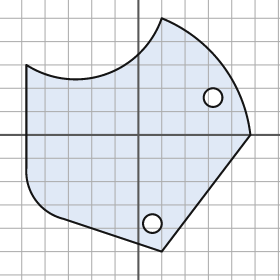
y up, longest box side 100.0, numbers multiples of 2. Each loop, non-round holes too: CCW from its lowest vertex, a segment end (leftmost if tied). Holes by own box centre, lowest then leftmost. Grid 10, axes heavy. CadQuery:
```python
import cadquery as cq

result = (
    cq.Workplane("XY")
    .moveTo(10.0, -50.0)
    .lineTo(48.0, 0.0)
    .threePointArc((36.0, 30.0), (10.0, 50.0))
    .threePointArc((-14.0, 26.0), (-48.0, 30.0))
    .lineTo(-48.0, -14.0)
    .threePointArc((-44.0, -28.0), (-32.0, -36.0))
    .close()
    .moveTo(6.0, -38.0)
    .circle(4.0)
    .moveTo(32.0, 16.0)
    .circle(4.0)
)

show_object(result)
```